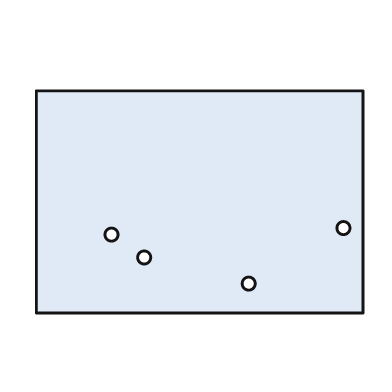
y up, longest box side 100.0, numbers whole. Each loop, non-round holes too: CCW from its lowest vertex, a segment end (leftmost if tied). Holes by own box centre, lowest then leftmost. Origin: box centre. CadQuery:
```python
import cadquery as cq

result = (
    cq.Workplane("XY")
    .moveTo(-50.0, -34.0)
    .lineTo(50.0, -34.0)
    .lineTo(50.0, 34.0)
    .lineTo(-50.0, 34.0)
    .close()
    .moveTo(15.0, -25.0)
    .circle(2.0)
    .moveTo(-17.0, -17.0)
    .circle(2.0)
    .moveTo(-27.0, -10.0)
    .circle(2.0)
    .moveTo(44.0, -8.0)
    .circle(2.0)
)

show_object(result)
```